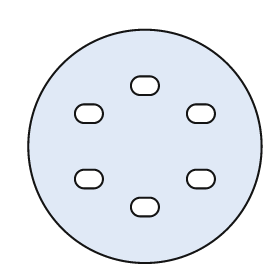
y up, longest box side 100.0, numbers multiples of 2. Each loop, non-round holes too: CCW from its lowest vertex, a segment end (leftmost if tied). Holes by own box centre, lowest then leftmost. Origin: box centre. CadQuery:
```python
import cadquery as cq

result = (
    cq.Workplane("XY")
    .moveTo(0.0, 0.0)
    .circle(50.0)
    .moveTo(-2.0, -30.0)
    .lineTo(2.0, -30.0)
    .threePointArc((6.0, -26.0), (2.0, -22.0))
    .lineTo(-2.0, -22.0)
    .threePointArc((-6.0, -26.0), (-2.0, -30.0))
    .close()
    .moveTo(-26.0, -18.0)
    .lineTo(-22.0, -18.0)
    .threePointArc((-18.0, -14.0), (-22.0, -10.0))
    .lineTo(-26.0, -10.0)
    .threePointArc((-30.0, -14.0), (-26.0, -18.0))
    .close()
    .moveTo(22.0, -18.0)
    .lineTo(26.0, -18.0)
    .threePointArc((30.0, -14.0), (26.0, -10.0))
    .lineTo(22.0, -10.0)
    .threePointArc((18.0, -14.0), (22.0, -18.0))
    .close()
    .moveTo(-26.0, 10.0)
    .lineTo(-22.0, 10.0)
    .threePointArc((-18.0, 14.0), (-22.0, 18.0))
    .lineTo(-26.0, 18.0)
    .threePointArc((-30.0, 14.0), (-26.0, 10.0))
    .close()
    .moveTo(22.0, 10.0)
    .lineTo(26.0, 10.0)
    .threePointArc((30.0, 14.0), (26.0, 18.0))
    .lineTo(22.0, 18.0)
    .threePointArc((18.0, 14.0), (22.0, 10.0))
    .close()
    .moveTo(-2.0, 22.0)
    .lineTo(2.0, 22.0)
    .threePointArc((6.0, 26.0), (2.0, 30.0))
    .lineTo(-2.0, 30.0)
    .threePointArc((-6.0, 26.0), (-2.0, 22.0))
    .close()
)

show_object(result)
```